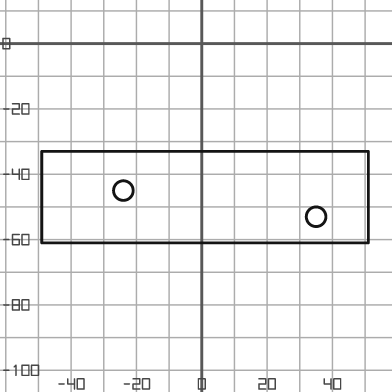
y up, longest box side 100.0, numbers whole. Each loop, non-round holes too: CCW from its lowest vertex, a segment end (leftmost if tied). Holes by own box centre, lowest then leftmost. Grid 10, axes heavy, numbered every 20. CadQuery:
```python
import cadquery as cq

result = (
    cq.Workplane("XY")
    .moveTo(-49.0, -61.0)
    .lineTo(51.0, -61.0)
    .lineTo(51.0, -33.0)
    .lineTo(-49.0, -33.0)
    .close()
    .moveTo(35.0, -53.0)
    .circle(3.0)
    .moveTo(-24.0, -45.0)
    .circle(3.0)
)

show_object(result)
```